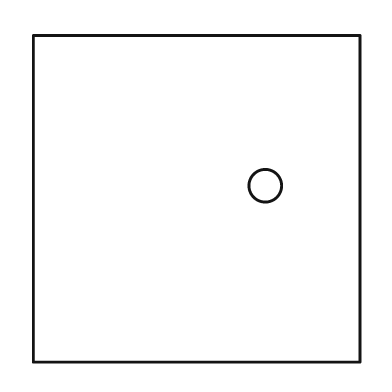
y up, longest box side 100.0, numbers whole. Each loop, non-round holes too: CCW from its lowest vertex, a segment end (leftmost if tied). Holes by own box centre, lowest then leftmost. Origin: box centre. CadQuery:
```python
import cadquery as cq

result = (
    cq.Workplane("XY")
    .moveTo(-50.0, -50.0)
    .lineTo(50.0, -50.0)
    .lineTo(50.0, 50.0)
    .lineTo(-50.0, 50.0)
    .close()
    .moveTo(21.0, 4.0)
    .circle(5.0)
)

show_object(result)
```